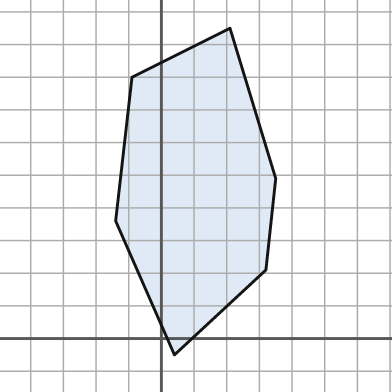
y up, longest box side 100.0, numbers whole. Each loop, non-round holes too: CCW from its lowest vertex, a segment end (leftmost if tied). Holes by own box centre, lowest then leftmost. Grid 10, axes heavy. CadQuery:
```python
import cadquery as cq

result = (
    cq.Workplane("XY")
    .moveTo(4.0, -5.0)
    .lineTo(32.0, 21.0)
    .lineTo(35.0, 49.0)
    .lineTo(21.0, 95.0)
    .lineTo(-9.0, 80.0)
    .lineTo(-14.0, 36.0)
    .close()
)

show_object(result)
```